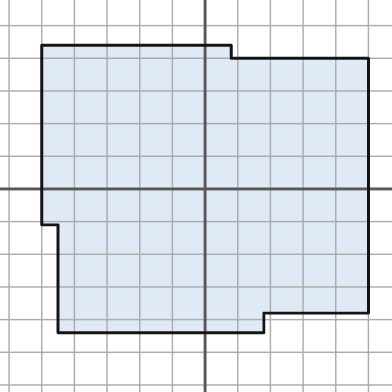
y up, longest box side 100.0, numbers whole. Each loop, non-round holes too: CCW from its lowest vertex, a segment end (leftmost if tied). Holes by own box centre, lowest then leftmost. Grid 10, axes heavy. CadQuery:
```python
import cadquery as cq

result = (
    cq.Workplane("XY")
    .moveTo(-45.0, -44.0)
    .lineTo(18.0, -44.0)
    .lineTo(18.0, -38.0)
    .lineTo(50.0, -38.0)
    .lineTo(50.0, 40.0)
    .lineTo(8.0, 40.0)
    .lineTo(8.0, 44.0)
    .lineTo(-50.0, 44.0)
    .lineTo(-50.0, -11.0)
    .lineTo(-45.0, -11.0)
    .close()
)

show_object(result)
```